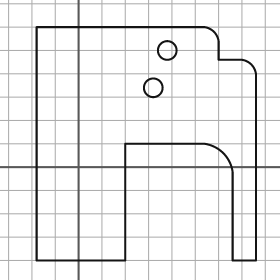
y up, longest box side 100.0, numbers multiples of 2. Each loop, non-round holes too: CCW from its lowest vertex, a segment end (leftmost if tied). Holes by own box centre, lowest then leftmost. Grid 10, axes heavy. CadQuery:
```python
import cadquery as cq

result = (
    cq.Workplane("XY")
    .moveTo(-18.0, -40.0)
    .lineTo(20.0, -40.0)
    .lineTo(20.0, 10.0)
    .lineTo(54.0, 10.0)
    .threePointArc((62.0, 6.0), (66.0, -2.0))
    .lineTo(66.0, -40.0)
    .lineTo(76.0, -40.0)
    .lineTo(76.0, 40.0)
    .threePointArc((74.0, 44.0), (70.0, 46.0))
    .lineTo(60.0, 46.0)
    .lineTo(60.0, 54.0)
    .threePointArc((58.0, 58.0), (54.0, 60.0))
    .lineTo(-18.0, 60.0)
    .close()
    .moveTo(32.0, 34.0)
    .circle(4.0)
    .moveTo(38.0, 50.0)
    .circle(4.0)
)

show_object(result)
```